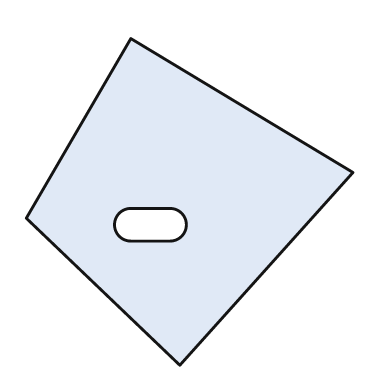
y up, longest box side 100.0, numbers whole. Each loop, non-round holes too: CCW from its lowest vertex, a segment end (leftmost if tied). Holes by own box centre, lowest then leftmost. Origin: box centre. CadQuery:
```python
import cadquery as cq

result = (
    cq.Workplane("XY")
    .moveTo(-3.0, -50.0)
    .lineTo(50.0, 9.0)
    .lineTo(-18.0, 50.0)
    .lineTo(-50.0, -5.0)
    .close()
    .moveTo(-18.0, -12.0)
    .lineTo(-6.0, -12.0)
    .threePointArc((-1.0, -7.0), (-6.0, -2.0))
    .lineTo(-18.0, -2.0)
    .threePointArc((-23.0, -7.0), (-18.0, -12.0))
    .close()
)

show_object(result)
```